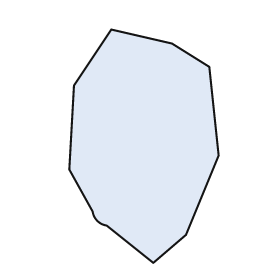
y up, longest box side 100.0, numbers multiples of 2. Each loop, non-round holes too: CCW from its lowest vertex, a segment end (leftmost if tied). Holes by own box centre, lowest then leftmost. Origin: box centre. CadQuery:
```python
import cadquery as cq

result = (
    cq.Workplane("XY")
    .moveTo(4.0, -50.0)
    .lineTo(18.0, -38.0)
    .lineTo(32.0, -4.0)
    .lineTo(28.0, 34.0)
    .lineTo(12.0, 44.0)
    .lineTo(-14.0, 50.0)
    .lineTo(-30.0, 26.0)
    .lineTo(-32.0, -10.0)
    .lineTo(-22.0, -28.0)
    .threePointArc((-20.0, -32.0), (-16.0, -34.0))
    .close()
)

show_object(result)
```